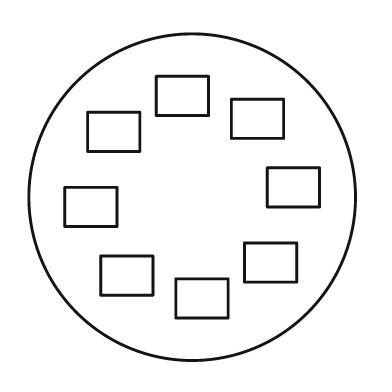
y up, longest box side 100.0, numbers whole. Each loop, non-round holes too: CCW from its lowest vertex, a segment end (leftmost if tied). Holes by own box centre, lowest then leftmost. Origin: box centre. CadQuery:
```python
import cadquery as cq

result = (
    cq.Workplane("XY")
    .moveTo(0.0, 0.0)
    .circle(50.0)
    .moveTo(-5.0, -37.0)
    .lineTo(11.0, -37.0)
    .lineTo(11.0, -25.0)
    .lineTo(-5.0, -25.0)
    .close()
    .moveTo(-28.0, -30.0)
    .lineTo(-12.0, -30.0)
    .lineTo(-12.0, -18.0)
    .lineTo(-28.0, -18.0)
    .close()
    .moveTo(16.0, -26.0)
    .lineTo(32.0, -26.0)
    .lineTo(32.0, -14.0)
    .lineTo(16.0, -14.0)
    .close()
    .moveTo(-39.0, -9.0)
    .lineTo(-23.0, -9.0)
    .lineTo(-23.0, 3.0)
    .lineTo(-39.0, 3.0)
    .close()
    .moveTo(23.0, -3.0)
    .lineTo(39.0, -3.0)
    .lineTo(39.0, 9.0)
    .lineTo(23.0, 9.0)
    .close()
    .moveTo(-32.0, 14.0)
    .lineTo(-16.0, 14.0)
    .lineTo(-16.0, 26.0)
    .lineTo(-32.0, 26.0)
    .close()
    .moveTo(12.0, 18.0)
    .lineTo(28.0, 18.0)
    .lineTo(28.0, 30.0)
    .lineTo(12.0, 30.0)
    .close()
    .moveTo(-11.0, 25.0)
    .lineTo(5.0, 25.0)
    .lineTo(5.0, 37.0)
    .lineTo(-11.0, 37.0)
    .close()
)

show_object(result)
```